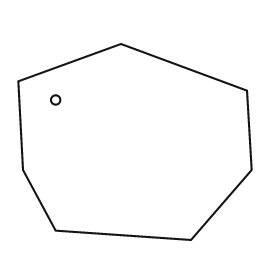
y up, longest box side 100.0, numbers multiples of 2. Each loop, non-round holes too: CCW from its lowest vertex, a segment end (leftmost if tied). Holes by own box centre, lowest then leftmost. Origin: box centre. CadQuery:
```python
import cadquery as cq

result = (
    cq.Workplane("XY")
    .moveTo(24.0, -42.0)
    .lineTo(50.0, -12.0)
    .lineTo(48.0, 22.0)
    .lineTo(-6.0, 42.0)
    .lineTo(-50.0, 26.0)
    .lineTo(-48.0, -12.0)
    .lineTo(-34.0, -38.0)
    .close()
    .moveTo(-34.0, 18.0)
    .circle(2.0)
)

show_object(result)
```